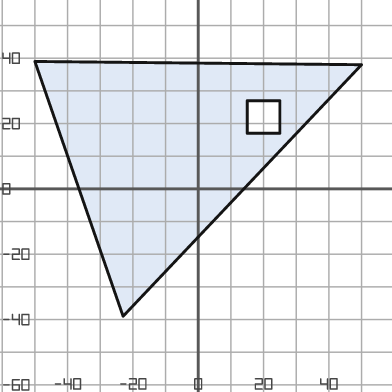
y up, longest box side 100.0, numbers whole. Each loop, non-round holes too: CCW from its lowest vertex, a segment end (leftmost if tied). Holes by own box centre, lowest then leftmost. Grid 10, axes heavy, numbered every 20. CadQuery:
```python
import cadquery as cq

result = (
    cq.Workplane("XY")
    .moveTo(-23.0, -39.0)
    .lineTo(50.0, 38.0)
    .lineTo(-50.0, 39.0)
    .close()
    .moveTo(15.0, 17.0)
    .lineTo(25.0, 17.0)
    .lineTo(25.0, 27.0)
    .lineTo(15.0, 27.0)
    .close()
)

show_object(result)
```